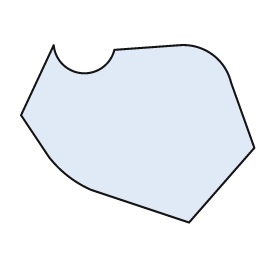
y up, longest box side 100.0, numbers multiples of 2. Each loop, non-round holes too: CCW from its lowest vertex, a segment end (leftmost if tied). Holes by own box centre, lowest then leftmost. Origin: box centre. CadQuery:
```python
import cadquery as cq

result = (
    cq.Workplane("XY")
    .moveTo(22.0, -38.0)
    .lineTo(50.0, -6.0)
    .lineTo(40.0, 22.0)
    .threePointArc((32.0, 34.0), (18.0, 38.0))
    .lineTo(-10.0, 36.0)
    .threePointArc((-24.0, 26.0), (-36.0, 38.0))
    .lineTo(-50.0, 8.0)
    .lineTo(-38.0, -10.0)
    .threePointArc((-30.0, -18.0), (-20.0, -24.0))
    .close()
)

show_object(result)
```